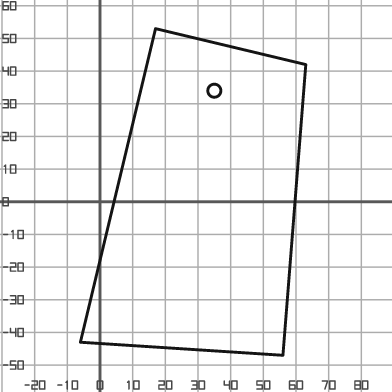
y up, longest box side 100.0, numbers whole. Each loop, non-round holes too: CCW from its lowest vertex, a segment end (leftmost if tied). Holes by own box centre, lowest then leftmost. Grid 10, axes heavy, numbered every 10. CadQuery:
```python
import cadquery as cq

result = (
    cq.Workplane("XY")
    .moveTo(56.0, -47.0)
    .lineTo(63.0, 42.0)
    .lineTo(17.0, 53.0)
    .lineTo(-6.0, -43.0)
    .close()
    .moveTo(35.0, 34.0)
    .circle(2.0)
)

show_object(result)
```